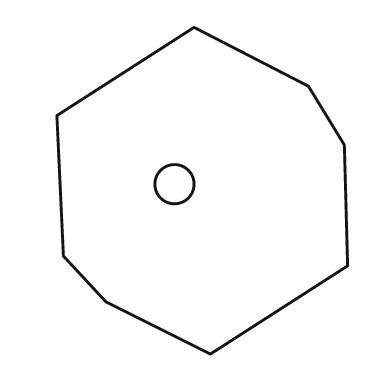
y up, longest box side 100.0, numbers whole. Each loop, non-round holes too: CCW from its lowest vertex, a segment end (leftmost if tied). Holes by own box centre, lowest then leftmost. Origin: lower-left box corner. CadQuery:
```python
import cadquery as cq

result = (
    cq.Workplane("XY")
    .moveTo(47.0, 0.0)
    .lineTo(89.0, 27.0)
    .lineTo(88.0, 64.0)
    .lineTo(77.0, 82.0)
    .lineTo(42.0, 100.0)
    .lineTo(0.0, 73.0)
    .lineTo(2.0, 30.0)
    .lineTo(15.0, 16.0)
    .close()
    .moveTo(36.0, 52.0)
    .circle(6.0)
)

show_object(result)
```